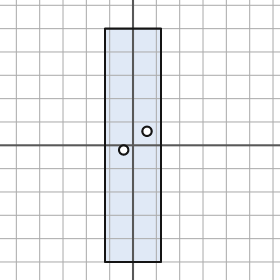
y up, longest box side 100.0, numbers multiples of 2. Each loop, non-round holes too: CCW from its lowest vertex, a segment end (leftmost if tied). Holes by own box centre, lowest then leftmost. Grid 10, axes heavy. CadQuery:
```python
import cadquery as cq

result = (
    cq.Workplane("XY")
    .moveTo(-12.0, -50.0)
    .lineTo(12.0, -50.0)
    .lineTo(12.0, 50.0)
    .lineTo(-12.0, 50.0)
    .close()
    .moveTo(-4.0, -2.0)
    .circle(2.0)
    .moveTo(6.0, 6.0)
    .circle(2.0)
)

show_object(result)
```